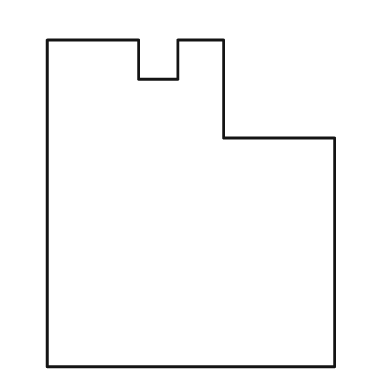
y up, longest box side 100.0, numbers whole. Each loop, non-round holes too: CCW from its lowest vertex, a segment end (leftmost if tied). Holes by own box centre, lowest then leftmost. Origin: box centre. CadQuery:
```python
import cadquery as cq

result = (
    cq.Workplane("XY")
    .moveTo(-44.0, -50.0)
    .lineTo(44.0, -50.0)
    .lineTo(44.0, 20.0)
    .lineTo(10.0, 20.0)
    .lineTo(10.0, 50.0)
    .lineTo(-4.0, 50.0)
    .lineTo(-4.0, 38.0)
    .lineTo(-16.0, 38.0)
    .lineTo(-16.0, 50.0)
    .lineTo(-44.0, 50.0)
    .close()
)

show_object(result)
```